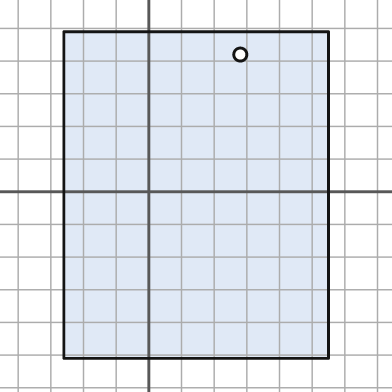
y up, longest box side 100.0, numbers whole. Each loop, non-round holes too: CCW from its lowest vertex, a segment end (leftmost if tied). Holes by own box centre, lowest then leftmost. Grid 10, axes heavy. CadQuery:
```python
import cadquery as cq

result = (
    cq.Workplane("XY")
    .moveTo(-26.0, -51.0)
    .lineTo(55.0, -51.0)
    .lineTo(55.0, 49.0)
    .lineTo(-26.0, 49.0)
    .close()
    .moveTo(28.0, 42.0)
    .circle(2.0)
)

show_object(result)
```